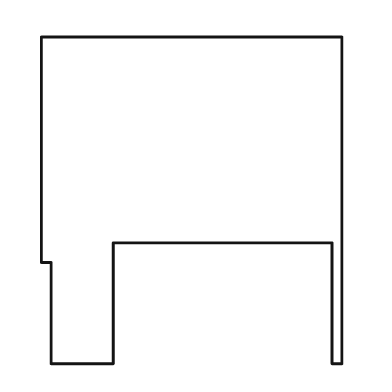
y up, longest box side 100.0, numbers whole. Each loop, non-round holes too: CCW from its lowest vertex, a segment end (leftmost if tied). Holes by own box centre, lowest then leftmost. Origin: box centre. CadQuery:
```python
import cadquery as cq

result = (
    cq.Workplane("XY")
    .moveTo(-43.0, -50.0)
    .lineTo(-24.0, -50.0)
    .lineTo(-24.0, -13.0)
    .lineTo(43.0, -13.0)
    .lineTo(43.0, -50.0)
    .lineTo(46.0, -50.0)
    .lineTo(46.0, 50.0)
    .lineTo(-46.0, 50.0)
    .lineTo(-46.0, -19.0)
    .lineTo(-43.0, -19.0)
    .close()
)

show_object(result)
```